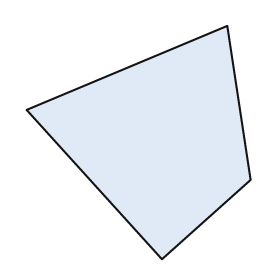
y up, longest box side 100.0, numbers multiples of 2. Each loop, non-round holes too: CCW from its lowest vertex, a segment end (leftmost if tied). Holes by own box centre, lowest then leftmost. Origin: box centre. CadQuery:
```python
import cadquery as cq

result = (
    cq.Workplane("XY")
    .moveTo(10.0, -50.0)
    .lineTo(48.0, -16.0)
    .lineTo(38.0, 50.0)
    .lineTo(-48.0, 14.0)
    .close()
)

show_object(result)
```